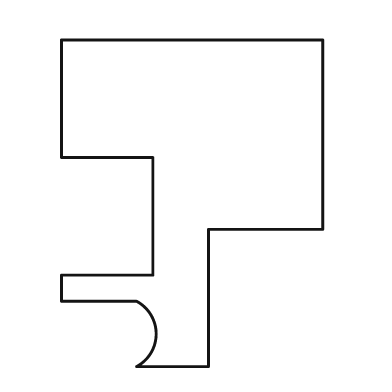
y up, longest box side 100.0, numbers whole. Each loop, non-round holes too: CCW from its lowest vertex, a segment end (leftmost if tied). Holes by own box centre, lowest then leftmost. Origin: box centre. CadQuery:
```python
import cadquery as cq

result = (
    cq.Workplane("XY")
    .moveTo(-17.0, -50.0)
    .lineTo(5.0, -50.0)
    .lineTo(5.0, -8.0)
    .lineTo(40.0, -8.0)
    .lineTo(40.0, 50.0)
    .lineTo(-40.0, 50.0)
    .lineTo(-40.0, 14.0)
    .lineTo(-12.0, 14.0)
    .lineTo(-12.0, -22.0)
    .lineTo(-40.0, -22.0)
    .lineTo(-40.0, -30.0)
    .lineTo(-17.0, -30.0)
    .threePointArc((-11.0, -40.0), (-17.0, -50.0))
    .close()
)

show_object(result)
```